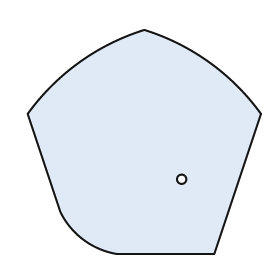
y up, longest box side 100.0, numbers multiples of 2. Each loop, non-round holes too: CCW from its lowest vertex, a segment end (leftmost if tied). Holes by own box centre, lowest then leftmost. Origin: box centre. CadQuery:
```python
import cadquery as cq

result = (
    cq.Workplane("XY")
    .moveTo(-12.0, -48.0)
    .lineTo(30.0, -48.0)
    .lineTo(50.0, 12.0)
    .threePointArc((28.0, 34.0), (0.0, 48.0))
    .threePointArc((-28.0, 34.0), (-50.0, 12.0))
    .lineTo(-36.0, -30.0)
    .threePointArc((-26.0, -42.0), (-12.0, -48.0))
    .close()
    .moveTo(16.0, -16.0)
    .circle(2.0)
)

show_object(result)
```